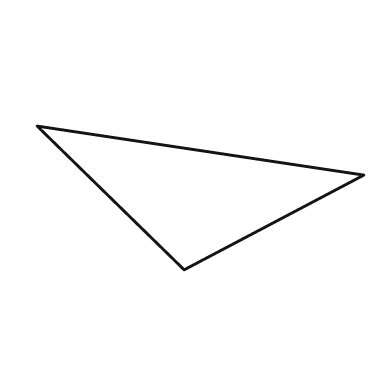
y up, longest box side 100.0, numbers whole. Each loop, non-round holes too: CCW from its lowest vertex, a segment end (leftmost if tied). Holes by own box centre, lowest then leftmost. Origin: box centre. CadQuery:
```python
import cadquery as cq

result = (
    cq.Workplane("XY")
    .moveTo(-5.0, -22.0)
    .lineTo(50.0, 7.0)
    .lineTo(-50.0, 22.0)
    .close()
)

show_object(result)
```